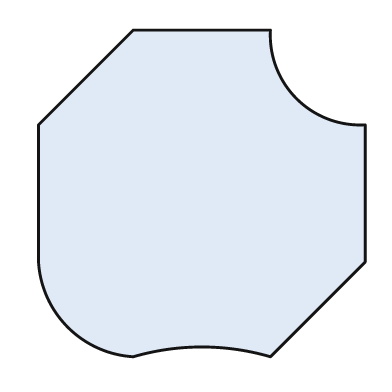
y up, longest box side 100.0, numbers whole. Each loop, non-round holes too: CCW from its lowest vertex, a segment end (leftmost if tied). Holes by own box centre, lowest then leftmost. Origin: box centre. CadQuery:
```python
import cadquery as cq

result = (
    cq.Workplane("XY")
    .moveTo(-21.0, -50.0)
    .threePointArc((0.0, -47.0), (21.0, -50.0))
    .lineTo(50.0, -21.0)
    .lineTo(50.0, 21.0)
    .threePointArc((29.0, 29.0), (21.0, 50.0))
    .lineTo(-21.0, 50.0)
    .lineTo(-50.0, 21.0)
    .lineTo(-50.0, -21.0)
    .threePointArc((-41.0, -41.0), (-21.0, -50.0))
    .close()
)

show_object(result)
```